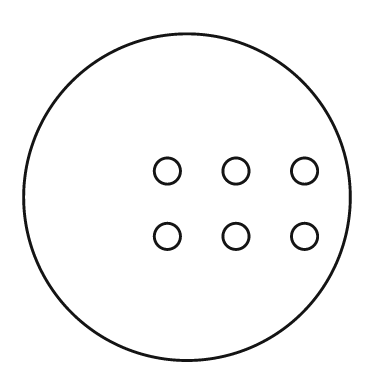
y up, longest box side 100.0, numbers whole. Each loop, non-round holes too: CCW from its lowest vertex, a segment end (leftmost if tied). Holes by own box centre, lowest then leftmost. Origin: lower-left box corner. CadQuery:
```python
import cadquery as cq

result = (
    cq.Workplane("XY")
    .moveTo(50.0, 50.0)
    .circle(50.0)
    .moveTo(44.0, 38.0)
    .circle(4.0)
    .moveTo(65.0, 38.0)
    .circle(4.0)
    .moveTo(86.0, 38.0)
    .circle(4.0)
    .moveTo(44.0, 58.0)
    .circle(4.0)
    .moveTo(65.0, 58.0)
    .circle(4.0)
    .moveTo(86.0, 58.0)
    .circle(4.0)
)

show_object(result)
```